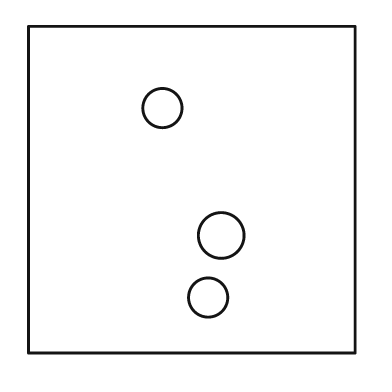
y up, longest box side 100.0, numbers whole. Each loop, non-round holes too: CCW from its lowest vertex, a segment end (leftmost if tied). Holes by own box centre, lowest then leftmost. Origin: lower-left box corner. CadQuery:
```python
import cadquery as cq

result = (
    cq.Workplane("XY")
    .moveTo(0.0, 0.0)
    .lineTo(100.0, 0.0)
    .lineTo(100.0, 100.0)
    .lineTo(0.0, 100.0)
    .close()
    .moveTo(55.0, 17.0)
    .circle(6.0)
    .moveTo(59.0, 36.0)
    .circle(7.0)
    .moveTo(41.0, 75.0)
    .circle(6.0)
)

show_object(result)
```